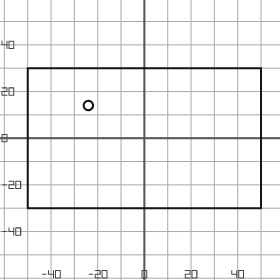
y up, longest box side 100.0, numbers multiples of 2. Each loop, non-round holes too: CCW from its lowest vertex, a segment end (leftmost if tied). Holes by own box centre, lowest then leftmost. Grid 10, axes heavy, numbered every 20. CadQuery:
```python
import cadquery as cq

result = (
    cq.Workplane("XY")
    .moveTo(-50.0, -30.0)
    .lineTo(50.0, -30.0)
    .lineTo(50.0, 30.0)
    .lineTo(-50.0, 30.0)
    .close()
    .moveTo(-24.0, 14.0)
    .circle(2.0)
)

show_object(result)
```